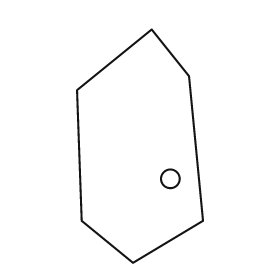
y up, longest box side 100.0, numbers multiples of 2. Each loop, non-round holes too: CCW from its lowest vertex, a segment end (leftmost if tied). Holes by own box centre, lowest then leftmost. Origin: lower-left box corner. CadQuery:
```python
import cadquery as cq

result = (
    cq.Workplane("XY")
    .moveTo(24.0, 0.0)
    .lineTo(54.0, 18.0)
    .lineTo(48.0, 80.0)
    .lineTo(32.0, 100.0)
    .lineTo(0.0, 74.0)
    .lineTo(2.0, 18.0)
    .close()
    .moveTo(40.0, 36.0)
    .circle(4.0)
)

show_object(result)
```